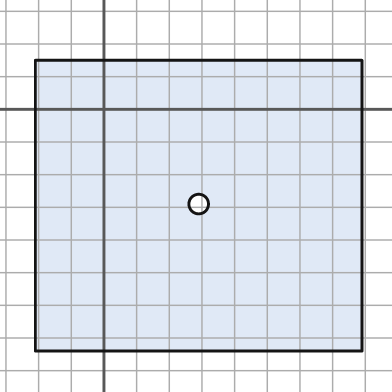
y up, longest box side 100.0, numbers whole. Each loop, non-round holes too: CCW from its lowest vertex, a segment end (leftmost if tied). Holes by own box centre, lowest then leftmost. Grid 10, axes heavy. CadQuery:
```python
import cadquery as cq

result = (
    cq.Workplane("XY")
    .moveTo(-21.0, -74.0)
    .lineTo(79.0, -74.0)
    .lineTo(79.0, 15.0)
    .lineTo(-21.0, 15.0)
    .close()
    .moveTo(29.0, -29.0)
    .circle(3.0)
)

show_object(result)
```